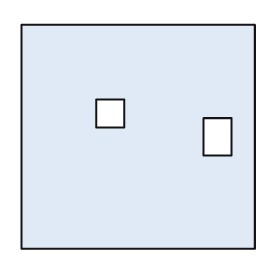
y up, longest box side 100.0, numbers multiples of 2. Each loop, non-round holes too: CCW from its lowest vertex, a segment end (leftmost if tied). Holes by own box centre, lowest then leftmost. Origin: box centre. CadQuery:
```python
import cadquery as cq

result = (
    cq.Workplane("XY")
    .moveTo(-50.0, -48.0)
    .lineTo(50.0, -48.0)
    .lineTo(50.0, 48.0)
    .lineTo(-50.0, 48.0)
    .close()
    .moveTo(28.0, -8.0)
    .lineTo(40.0, -8.0)
    .lineTo(40.0, 8.0)
    .lineTo(28.0, 8.0)
    .close()
    .moveTo(-18.0, 4.0)
    .lineTo(-6.0, 4.0)
    .lineTo(-6.0, 16.0)
    .lineTo(-18.0, 16.0)
    .close()
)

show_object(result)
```